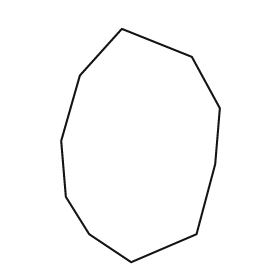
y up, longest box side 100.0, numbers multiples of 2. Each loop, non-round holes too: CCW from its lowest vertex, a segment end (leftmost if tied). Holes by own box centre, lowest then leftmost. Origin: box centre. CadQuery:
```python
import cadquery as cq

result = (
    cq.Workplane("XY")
    .moveTo(-4.0, -50.0)
    .lineTo(24.0, -38.0)
    .lineTo(32.0, -8.0)
    .lineTo(34.0, 16.0)
    .lineTo(22.0, 38.0)
    .lineTo(-8.0, 50.0)
    .lineTo(-26.0, 30.0)
    .lineTo(-34.0, 2.0)
    .lineTo(-32.0, -22.0)
    .lineTo(-22.0, -38.0)
    .close()
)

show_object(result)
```